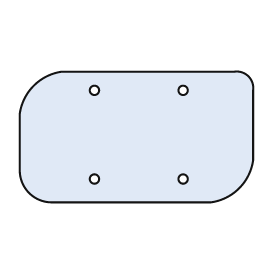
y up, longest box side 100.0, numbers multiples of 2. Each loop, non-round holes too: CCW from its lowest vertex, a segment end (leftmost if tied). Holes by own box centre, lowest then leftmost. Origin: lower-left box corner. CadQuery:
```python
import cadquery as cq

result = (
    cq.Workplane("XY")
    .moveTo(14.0, 0.0)
    .lineTo(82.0, 0.0)
    .threePointArc((94.0, 6.0), (100.0, 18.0))
    .lineTo(100.0, 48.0)
    .threePointArc((98.0, 54.0), (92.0, 56.0))
    .lineTo(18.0, 56.0)
    .threePointArc((6.0, 50.0), (0.0, 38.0))
    .lineTo(0.0, 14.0)
    .threePointArc((4.0, 4.0), (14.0, 0.0))
    .close()
    .moveTo(32.0, 10.0)
    .circle(2.0)
    .moveTo(70.0, 10.0)
    .circle(2.0)
    .moveTo(32.0, 48.0)
    .circle(2.0)
    .moveTo(70.0, 48.0)
    .circle(2.0)
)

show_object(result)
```